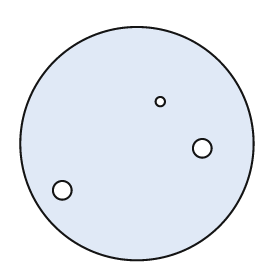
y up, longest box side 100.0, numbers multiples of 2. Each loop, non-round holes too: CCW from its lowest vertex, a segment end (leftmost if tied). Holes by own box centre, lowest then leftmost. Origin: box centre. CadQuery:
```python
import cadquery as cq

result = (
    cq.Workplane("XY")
    .moveTo(0.0, 0.0)
    .circle(50.0)
    .moveTo(-32.0, -20.0)
    .circle(4.0)
    .moveTo(28.0, -2.0)
    .circle(4.0)
    .moveTo(10.0, 18.0)
    .circle(2.0)
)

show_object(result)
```